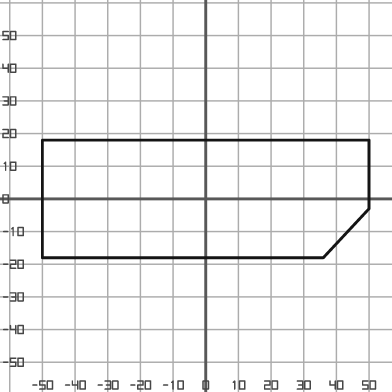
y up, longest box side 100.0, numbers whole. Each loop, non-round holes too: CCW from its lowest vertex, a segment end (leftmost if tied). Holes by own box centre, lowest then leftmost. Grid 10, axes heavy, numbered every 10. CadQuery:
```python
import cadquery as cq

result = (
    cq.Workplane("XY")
    .moveTo(-50.0, -18.0)
    .lineTo(36.0, -18.0)
    .lineTo(50.0, -3.0)
    .lineTo(50.0, 18.0)
    .lineTo(-50.0, 18.0)
    .close()
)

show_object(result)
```